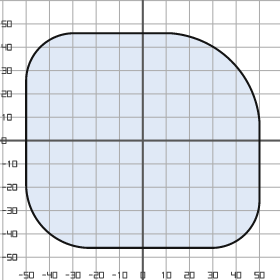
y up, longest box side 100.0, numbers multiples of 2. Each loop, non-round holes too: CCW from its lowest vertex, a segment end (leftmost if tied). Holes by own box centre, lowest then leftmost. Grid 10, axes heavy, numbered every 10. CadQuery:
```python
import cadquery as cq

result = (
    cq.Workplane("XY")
    .moveTo(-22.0, -46.0)
    .lineTo(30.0, -46.0)
    .threePointArc((44.0, -40.0), (50.0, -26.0))
    .lineTo(50.0, 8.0)
    .threePointArc((38.0, 34.0), (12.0, 46.0))
    .lineTo(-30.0, 46.0)
    .threePointArc((-44.0, 40.0), (-50.0, 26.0))
    .lineTo(-50.0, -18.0)
    .threePointArc((-42.0, -38.0), (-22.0, -46.0))
    .close()
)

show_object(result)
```